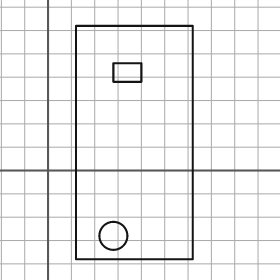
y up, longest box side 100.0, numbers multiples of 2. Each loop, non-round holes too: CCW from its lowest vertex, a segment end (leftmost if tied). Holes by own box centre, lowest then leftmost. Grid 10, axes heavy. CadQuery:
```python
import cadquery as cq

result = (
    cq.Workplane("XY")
    .moveTo(12.0, -38.0)
    .lineTo(62.0, -38.0)
    .lineTo(62.0, 62.0)
    .lineTo(12.0, 62.0)
    .close()
    .moveTo(28.0, -28.0)
    .circle(6.0)
    .moveTo(28.0, 38.0)
    .lineTo(40.0, 38.0)
    .lineTo(40.0, 46.0)
    .lineTo(28.0, 46.0)
    .close()
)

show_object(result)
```